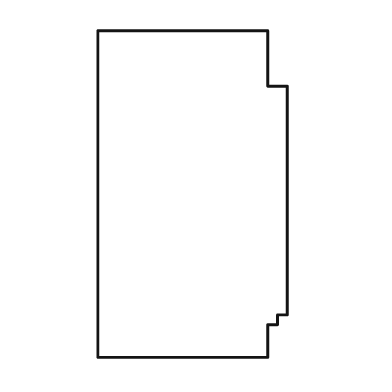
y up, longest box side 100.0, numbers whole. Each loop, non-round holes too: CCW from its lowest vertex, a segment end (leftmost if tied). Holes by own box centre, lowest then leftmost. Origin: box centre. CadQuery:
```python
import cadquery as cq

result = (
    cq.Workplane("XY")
    .moveTo(-29.0, -50.0)
    .lineTo(23.0, -50.0)
    .lineTo(23.0, -40.0)
    .lineTo(26.0, -40.0)
    .lineTo(26.0, -37.0)
    .lineTo(29.0, -37.0)
    .lineTo(29.0, 33.0)
    .lineTo(23.0, 33.0)
    .lineTo(23.0, 50.0)
    .lineTo(-29.0, 50.0)
    .close()
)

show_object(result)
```